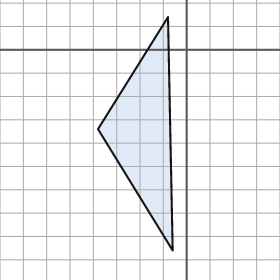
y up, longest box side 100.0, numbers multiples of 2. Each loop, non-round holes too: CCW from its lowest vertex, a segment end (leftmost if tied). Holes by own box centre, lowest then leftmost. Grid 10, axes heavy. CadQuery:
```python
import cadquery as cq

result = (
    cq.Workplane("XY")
    .moveTo(-6.0, -86.0)
    .lineTo(-8.0, 14.0)
    .lineTo(-38.0, -34.0)
    .close()
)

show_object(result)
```